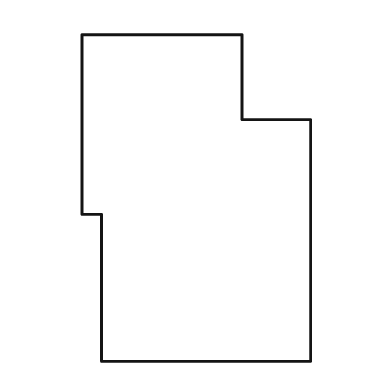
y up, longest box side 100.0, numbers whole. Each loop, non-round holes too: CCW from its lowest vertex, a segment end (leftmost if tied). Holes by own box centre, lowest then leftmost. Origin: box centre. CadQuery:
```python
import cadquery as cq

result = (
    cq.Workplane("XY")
    .moveTo(-29.0, -50.0)
    .lineTo(35.0, -50.0)
    .lineTo(35.0, 24.0)
    .lineTo(14.0, 24.0)
    .lineTo(14.0, 50.0)
    .lineTo(-35.0, 50.0)
    .lineTo(-35.0, -5.0)
    .lineTo(-29.0, -5.0)
    .close()
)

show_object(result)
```